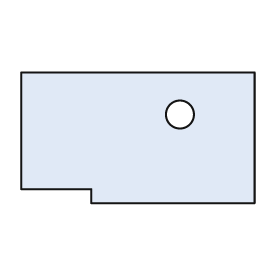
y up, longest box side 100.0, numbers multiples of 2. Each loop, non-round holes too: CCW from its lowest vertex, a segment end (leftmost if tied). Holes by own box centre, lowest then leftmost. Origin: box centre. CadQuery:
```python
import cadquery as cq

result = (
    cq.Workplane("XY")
    .moveTo(-20.0, -28.0)
    .lineTo(50.0, -28.0)
    .lineTo(50.0, 28.0)
    .lineTo(-50.0, 28.0)
    .lineTo(-50.0, -22.0)
    .lineTo(-20.0, -22.0)
    .close()
    .moveTo(18.0, 10.0)
    .circle(6.0)
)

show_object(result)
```